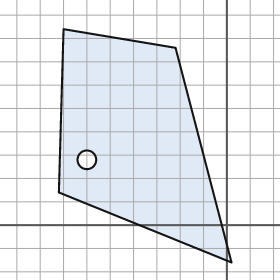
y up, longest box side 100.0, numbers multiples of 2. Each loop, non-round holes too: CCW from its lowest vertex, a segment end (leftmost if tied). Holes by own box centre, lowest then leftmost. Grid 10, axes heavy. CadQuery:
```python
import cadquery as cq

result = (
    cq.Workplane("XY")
    .moveTo(2.0, -16.0)
    .lineTo(-22.0, 76.0)
    .lineTo(-70.0, 84.0)
    .lineTo(-72.0, 14.0)
    .close()
    .moveTo(-60.0, 28.0)
    .circle(4.0)
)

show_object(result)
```